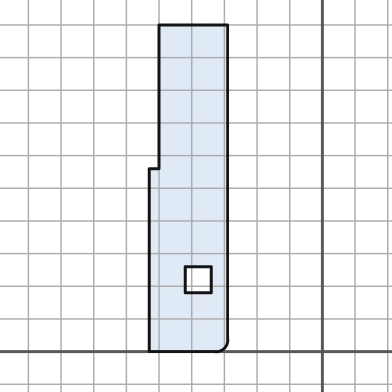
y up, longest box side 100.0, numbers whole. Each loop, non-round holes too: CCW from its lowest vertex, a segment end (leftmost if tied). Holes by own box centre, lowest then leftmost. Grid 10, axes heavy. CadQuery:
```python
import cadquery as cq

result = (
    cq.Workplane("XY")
    .moveTo(-53.0, 0.0)
    .lineTo(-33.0, 0.0)
    .threePointArc((-30.0, 1.0), (-29.0, 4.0))
    .lineTo(-29.0, 100.0)
    .lineTo(-50.0, 100.0)
    .lineTo(-50.0, 56.0)
    .lineTo(-53.0, 56.0)
    .close()
    .moveTo(-42.0, 18.0)
    .lineTo(-34.0, 18.0)
    .lineTo(-34.0, 26.0)
    .lineTo(-42.0, 26.0)
    .close()
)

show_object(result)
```